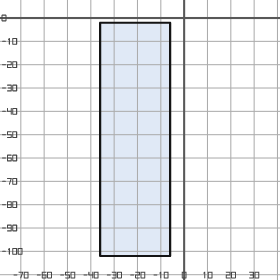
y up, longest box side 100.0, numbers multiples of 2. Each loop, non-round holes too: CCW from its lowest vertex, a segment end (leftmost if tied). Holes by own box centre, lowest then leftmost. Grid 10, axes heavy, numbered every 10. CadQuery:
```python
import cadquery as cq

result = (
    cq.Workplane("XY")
    .moveTo(-36.0, -102.0)
    .lineTo(-6.0, -102.0)
    .lineTo(-6.0, -2.0)
    .lineTo(-36.0, -2.0)
    .close()
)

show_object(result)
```